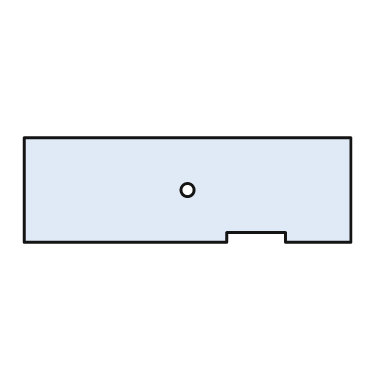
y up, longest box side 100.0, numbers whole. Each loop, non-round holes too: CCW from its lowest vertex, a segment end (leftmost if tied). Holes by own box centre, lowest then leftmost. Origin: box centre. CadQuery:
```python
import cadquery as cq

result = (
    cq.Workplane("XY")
    .moveTo(-50.0, -16.0)
    .lineTo(12.0, -16.0)
    .lineTo(12.0, -13.0)
    .lineTo(30.0, -13.0)
    .lineTo(30.0, -16.0)
    .lineTo(50.0, -16.0)
    .lineTo(50.0, 16.0)
    .lineTo(-50.0, 16.0)
    .close()
    .moveTo(0.0, 0.0)
    .circle(2.0)
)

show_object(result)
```